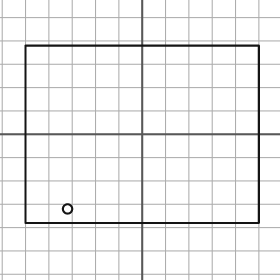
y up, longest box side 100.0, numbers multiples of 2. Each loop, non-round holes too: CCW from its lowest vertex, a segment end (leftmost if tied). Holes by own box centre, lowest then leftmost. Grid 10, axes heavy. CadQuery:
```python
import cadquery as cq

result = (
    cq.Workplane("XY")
    .moveTo(-50.0, -38.0)
    .lineTo(50.0, -38.0)
    .lineTo(50.0, 38.0)
    .lineTo(-50.0, 38.0)
    .close()
    .moveTo(-32.0, -32.0)
    .circle(2.0)
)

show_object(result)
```